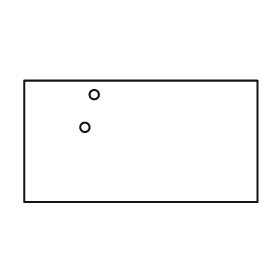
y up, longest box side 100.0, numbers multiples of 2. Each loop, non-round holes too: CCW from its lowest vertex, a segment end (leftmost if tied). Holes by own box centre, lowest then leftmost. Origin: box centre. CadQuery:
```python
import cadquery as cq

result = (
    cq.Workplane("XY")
    .moveTo(-50.0, -26.0)
    .lineTo(50.0, -26.0)
    .lineTo(50.0, 26.0)
    .lineTo(-50.0, 26.0)
    .close()
    .moveTo(-24.0, 6.0)
    .circle(2.0)
    .moveTo(-20.0, 20.0)
    .circle(2.0)
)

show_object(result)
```